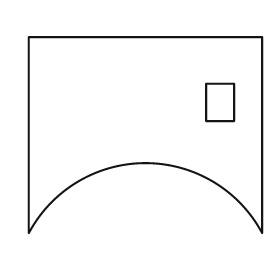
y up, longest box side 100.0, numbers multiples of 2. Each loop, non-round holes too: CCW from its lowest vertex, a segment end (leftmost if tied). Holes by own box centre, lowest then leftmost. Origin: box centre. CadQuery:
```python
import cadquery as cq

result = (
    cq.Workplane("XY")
    .moveTo(-50.0, -42.0)
    .threePointArc((0.0, -12.0), (50.0, -42.0))
    .lineTo(50.0, 42.0)
    .lineTo(-50.0, 42.0)
    .close()
    .moveTo(26.0, 6.0)
    .lineTo(38.0, 6.0)
    .lineTo(38.0, 22.0)
    .lineTo(26.0, 22.0)
    .close()
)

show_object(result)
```